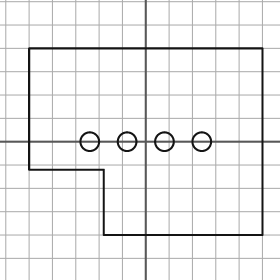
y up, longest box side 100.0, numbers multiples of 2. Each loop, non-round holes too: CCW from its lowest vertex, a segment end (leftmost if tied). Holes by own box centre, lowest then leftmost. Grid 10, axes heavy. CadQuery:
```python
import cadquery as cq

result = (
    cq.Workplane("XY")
    .moveTo(-18.0, -40.0)
    .lineTo(50.0, -40.0)
    .lineTo(50.0, 40.0)
    .lineTo(-50.0, 40.0)
    .lineTo(-50.0, -12.0)
    .lineTo(-18.0, -12.0)
    .close()
    .moveTo(-24.0, 0.0)
    .circle(4.0)
    .moveTo(-8.0, 0.0)
    .circle(4.0)
    .moveTo(8.0, 0.0)
    .circle(4.0)
    .moveTo(24.0, 0.0)
    .circle(4.0)
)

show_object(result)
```